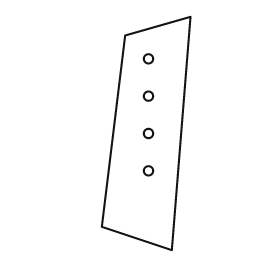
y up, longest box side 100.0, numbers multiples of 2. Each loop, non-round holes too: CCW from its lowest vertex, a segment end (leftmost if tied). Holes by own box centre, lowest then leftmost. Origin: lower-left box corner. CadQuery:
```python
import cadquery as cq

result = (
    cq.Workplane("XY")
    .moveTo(30.0, 0.0)
    .lineTo(38.0, 100.0)
    .lineTo(10.0, 92.0)
    .lineTo(0.0, 10.0)
    .close()
    .moveTo(20.0, 34.0)
    .circle(2.0)
    .moveTo(20.0, 50.0)
    .circle(2.0)
    .moveTo(20.0, 66.0)
    .circle(2.0)
    .moveTo(20.0, 82.0)
    .circle(2.0)
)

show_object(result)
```